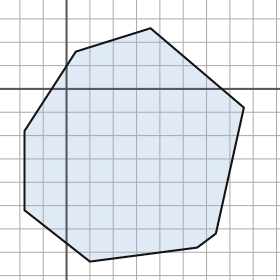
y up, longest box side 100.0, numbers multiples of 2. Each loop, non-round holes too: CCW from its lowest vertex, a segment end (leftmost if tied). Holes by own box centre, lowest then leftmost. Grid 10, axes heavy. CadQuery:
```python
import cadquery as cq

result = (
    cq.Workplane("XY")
    .moveTo(10.0, -74.0)
    .lineTo(56.0, -68.0)
    .lineTo(64.0, -62.0)
    .lineTo(76.0, -8.0)
    .lineTo(36.0, 26.0)
    .lineTo(4.0, 16.0)
    .lineTo(-18.0, -18.0)
    .lineTo(-18.0, -52.0)
    .close()
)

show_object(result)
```